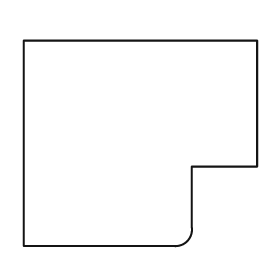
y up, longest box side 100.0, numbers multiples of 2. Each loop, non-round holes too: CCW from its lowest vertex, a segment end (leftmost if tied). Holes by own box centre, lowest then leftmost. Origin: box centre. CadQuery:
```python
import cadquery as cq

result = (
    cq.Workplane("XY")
    .moveTo(-50.0, -44.0)
    .lineTo(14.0, -44.0)
    .threePointArc((20.0, -42.0), (22.0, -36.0))
    .lineTo(22.0, -10.0)
    .lineTo(50.0, -10.0)
    .lineTo(50.0, 44.0)
    .lineTo(-50.0, 44.0)
    .close()
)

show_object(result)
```